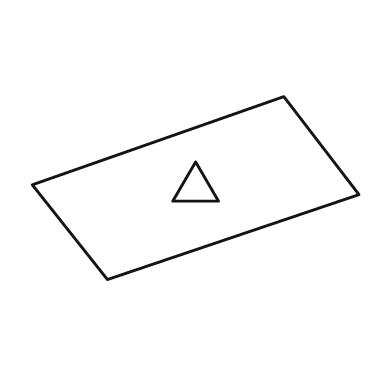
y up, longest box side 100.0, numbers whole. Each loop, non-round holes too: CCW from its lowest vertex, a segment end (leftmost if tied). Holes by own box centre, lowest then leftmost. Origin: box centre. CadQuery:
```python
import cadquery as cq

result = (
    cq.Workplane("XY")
    .moveTo(-27.0, -28.0)
    .lineTo(50.0, -2.0)
    .lineTo(27.0, 28.0)
    .lineTo(-50.0, 1.0)
    .close()
    .moveTo(-7.0, -4.0)
    .lineTo(7.0, -4.0)
    .lineTo(0.0, 8.0)
    .close()
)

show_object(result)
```